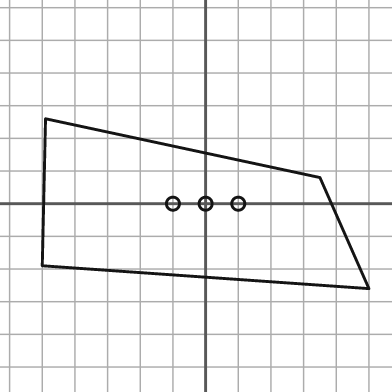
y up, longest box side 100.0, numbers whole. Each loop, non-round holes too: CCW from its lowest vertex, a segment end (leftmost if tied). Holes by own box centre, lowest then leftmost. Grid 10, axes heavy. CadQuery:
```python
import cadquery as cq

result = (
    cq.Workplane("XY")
    .moveTo(50.0, -26.0)
    .lineTo(35.0, 8.0)
    .lineTo(-49.0, 26.0)
    .lineTo(-50.0, -19.0)
    .close()
    .moveTo(-10.0, 0.0)
    .circle(2.0)
    .moveTo(0.0, 0.0)
    .circle(2.0)
    .moveTo(10.0, 0.0)
    .circle(2.0)
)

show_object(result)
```